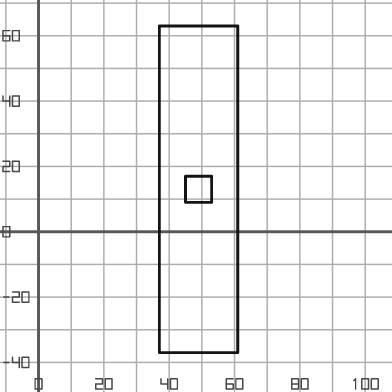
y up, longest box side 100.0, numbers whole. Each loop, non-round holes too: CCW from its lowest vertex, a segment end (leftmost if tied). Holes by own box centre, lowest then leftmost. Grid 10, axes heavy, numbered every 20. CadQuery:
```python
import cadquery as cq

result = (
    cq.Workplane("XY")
    .moveTo(37.0, -37.0)
    .lineTo(61.0, -37.0)
    .lineTo(61.0, 63.0)
    .lineTo(37.0, 63.0)
    .close()
    .moveTo(45.0, 9.0)
    .lineTo(53.0, 9.0)
    .lineTo(53.0, 17.0)
    .lineTo(45.0, 17.0)
    .close()
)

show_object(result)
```